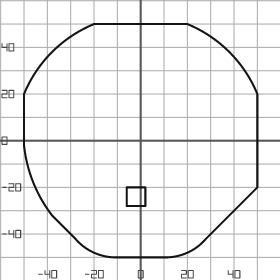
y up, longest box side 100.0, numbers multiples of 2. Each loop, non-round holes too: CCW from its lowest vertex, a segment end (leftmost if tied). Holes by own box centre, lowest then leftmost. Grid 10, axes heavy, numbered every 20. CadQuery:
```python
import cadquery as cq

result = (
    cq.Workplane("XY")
    .moveTo(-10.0, -50.0)
    .lineTo(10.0, -50.0)
    .threePointArc((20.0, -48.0), (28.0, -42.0))
    .lineTo(50.0, -20.0)
    .lineTo(50.0, 20.0)
    .threePointArc((38.0, 38.0), (20.0, 50.0))
    .lineTo(-20.0, 50.0)
    .threePointArc((-38.0, 38.0), (-50.0, 20.0))
    .lineTo(-50.0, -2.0)
    .threePointArc((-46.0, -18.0), (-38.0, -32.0))
    .lineTo(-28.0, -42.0)
    .threePointArc((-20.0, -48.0), (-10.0, -50.0))
    .close()
    .moveTo(-6.0, -28.0)
    .lineTo(2.0, -28.0)
    .lineTo(2.0, -20.0)
    .lineTo(-6.0, -20.0)
    .close()
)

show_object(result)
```